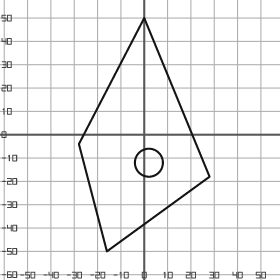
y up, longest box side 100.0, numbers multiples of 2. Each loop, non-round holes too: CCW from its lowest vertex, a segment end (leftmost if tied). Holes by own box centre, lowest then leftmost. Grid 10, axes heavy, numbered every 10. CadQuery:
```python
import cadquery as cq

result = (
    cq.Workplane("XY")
    .moveTo(-16.0, -50.0)
    .lineTo(28.0, -18.0)
    .lineTo(0.0, 50.0)
    .lineTo(-28.0, -4.0)
    .close()
    .moveTo(2.0, -12.0)
    .circle(6.0)
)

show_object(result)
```